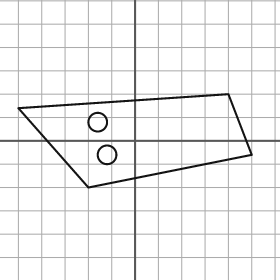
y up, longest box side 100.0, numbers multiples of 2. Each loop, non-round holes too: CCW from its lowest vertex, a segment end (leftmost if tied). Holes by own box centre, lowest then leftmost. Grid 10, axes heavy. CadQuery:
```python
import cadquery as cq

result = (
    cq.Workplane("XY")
    .moveTo(-20.0, -20.0)
    .lineTo(50.0, -6.0)
    .lineTo(40.0, 20.0)
    .lineTo(-50.0, 14.0)
    .close()
    .moveTo(-12.0, -6.0)
    .circle(4.0)
    .moveTo(-16.0, 8.0)
    .circle(4.0)
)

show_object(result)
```